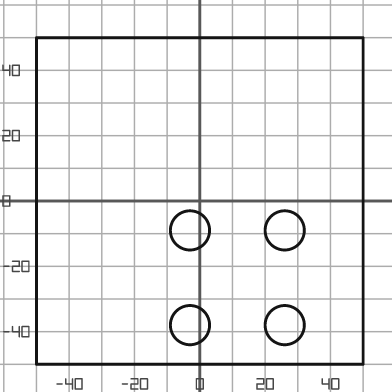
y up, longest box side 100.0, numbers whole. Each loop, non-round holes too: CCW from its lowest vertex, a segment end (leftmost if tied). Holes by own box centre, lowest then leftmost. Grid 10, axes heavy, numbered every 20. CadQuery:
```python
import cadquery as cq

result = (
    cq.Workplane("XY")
    .moveTo(-50.0, -50.0)
    .lineTo(50.0, -50.0)
    .lineTo(50.0, 50.0)
    .lineTo(-50.0, 50.0)
    .close()
    .moveTo(-3.0, -38.0)
    .circle(6.0)
    .moveTo(26.0, -38.0)
    .circle(6.0)
    .moveTo(-3.0, -9.0)
    .circle(6.0)
    .moveTo(26.0, -9.0)
    .circle(6.0)
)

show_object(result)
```